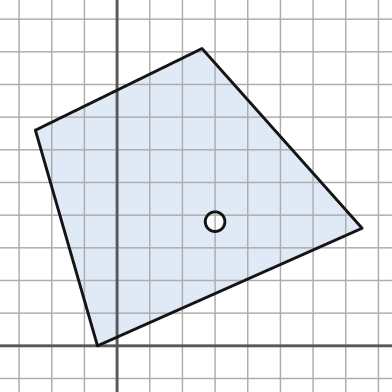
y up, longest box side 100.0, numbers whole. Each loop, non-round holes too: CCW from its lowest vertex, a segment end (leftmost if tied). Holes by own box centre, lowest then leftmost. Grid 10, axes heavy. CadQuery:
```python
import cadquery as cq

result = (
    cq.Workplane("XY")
    .moveTo(-6.0, 0.0)
    .lineTo(75.0, 36.0)
    .lineTo(26.0, 91.0)
    .lineTo(-25.0, 66.0)
    .close()
    .moveTo(30.0, 38.0)
    .circle(3.0)
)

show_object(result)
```